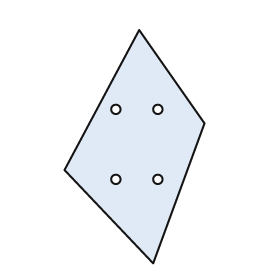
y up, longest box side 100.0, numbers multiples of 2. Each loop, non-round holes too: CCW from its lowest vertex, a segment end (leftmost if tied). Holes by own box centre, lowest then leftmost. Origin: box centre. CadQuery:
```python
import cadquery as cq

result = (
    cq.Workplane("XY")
    .moveTo(8.0, -50.0)
    .lineTo(30.0, 10.0)
    .lineTo(2.0, 50.0)
    .lineTo(-30.0, -10.0)
    .close()
    .moveTo(-8.0, -14.0)
    .circle(2.0)
    .moveTo(10.0, -14.0)
    .circle(2.0)
    .moveTo(-8.0, 16.0)
    .circle(2.0)
    .moveTo(10.0, 16.0)
    .circle(2.0)
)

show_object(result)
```